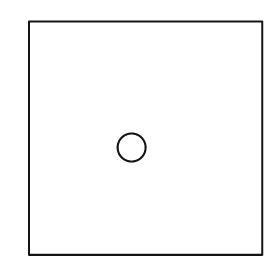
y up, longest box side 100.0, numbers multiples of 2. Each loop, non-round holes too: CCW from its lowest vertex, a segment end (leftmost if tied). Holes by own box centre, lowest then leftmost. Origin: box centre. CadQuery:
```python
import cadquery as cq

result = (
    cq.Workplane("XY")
    .moveTo(-50.0, -50.0)
    .lineTo(50.0, -50.0)
    .lineTo(50.0, 50.0)
    .lineTo(-50.0, 50.0)
    .close()
    .moveTo(-6.0, -4.0)
    .circle(6.0)
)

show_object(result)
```